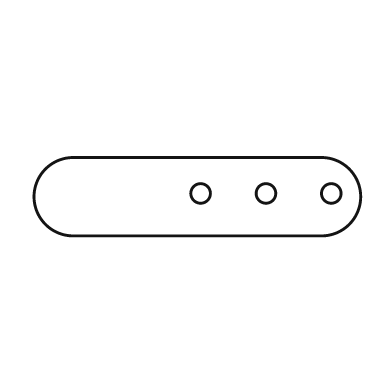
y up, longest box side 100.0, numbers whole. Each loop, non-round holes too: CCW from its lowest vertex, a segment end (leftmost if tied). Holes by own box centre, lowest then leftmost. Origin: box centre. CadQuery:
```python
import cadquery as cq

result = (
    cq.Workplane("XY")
    .moveTo(-38.0, -12.0)
    .lineTo(38.0, -12.0)
    .threePointArc((50.0, 0.0), (38.0, 12.0))
    .lineTo(-38.0, 12.0)
    .threePointArc((-50.0, 0.0), (-38.0, -12.0))
    .close()
    .moveTo(1.0, 1.0)
    .circle(3.0)
    .moveTo(21.0, 1.0)
    .circle(3.0)
    .moveTo(41.0, 1.0)
    .circle(3.0)
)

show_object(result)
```